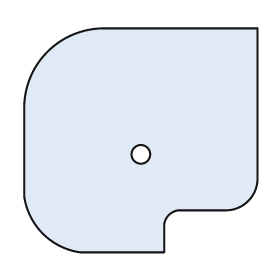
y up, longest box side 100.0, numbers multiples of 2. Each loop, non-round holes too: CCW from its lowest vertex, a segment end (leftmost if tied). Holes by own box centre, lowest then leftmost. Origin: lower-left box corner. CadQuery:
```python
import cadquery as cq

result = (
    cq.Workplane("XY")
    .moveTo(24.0, 0.0)
    .lineTo(60.0, 0.0)
    .lineTo(60.0, 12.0)
    .threePointArc((62.0, 16.0), (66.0, 18.0))
    .lineTo(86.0, 18.0)
    .threePointArc((96.0, 22.0), (100.0, 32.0))
    .lineTo(100.0, 96.0)
    .lineTo(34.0, 96.0)
    .threePointArc((10.0, 86.0), (0.0, 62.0))
    .lineTo(0.0, 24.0)
    .threePointArc((8.0, 8.0), (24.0, 0.0))
    .close()
    .moveTo(50.0, 42.0)
    .circle(4.0)
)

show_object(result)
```